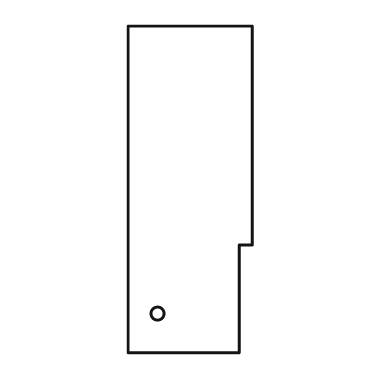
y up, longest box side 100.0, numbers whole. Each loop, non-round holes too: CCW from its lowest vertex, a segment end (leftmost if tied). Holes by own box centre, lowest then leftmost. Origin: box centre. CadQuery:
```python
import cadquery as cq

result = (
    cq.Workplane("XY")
    .moveTo(-19.0, -50.0)
    .lineTo(15.0, -50.0)
    .lineTo(15.0, -17.0)
    .lineTo(19.0, -17.0)
    .lineTo(19.0, 50.0)
    .lineTo(-19.0, 50.0)
    .close()
    .moveTo(-10.0, -38.0)
    .circle(2.0)
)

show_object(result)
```